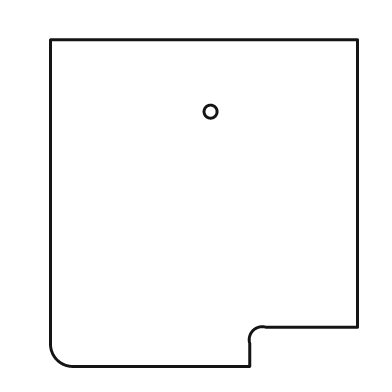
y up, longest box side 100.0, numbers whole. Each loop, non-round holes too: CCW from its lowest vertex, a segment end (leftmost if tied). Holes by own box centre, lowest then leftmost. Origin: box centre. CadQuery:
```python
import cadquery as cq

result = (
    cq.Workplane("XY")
    .moveTo(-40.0, -50.0)
    .lineTo(14.0, -50.0)
    .lineTo(14.0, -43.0)
    .threePointArc((15.0, -39.0), (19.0, -38.0))
    .lineTo(47.0, -38.0)
    .lineTo(47.0, 50.0)
    .lineTo(-47.0, 50.0)
    .lineTo(-47.0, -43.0)
    .threePointArc((-45.0, -48.0), (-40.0, -50.0))
    .close()
    .moveTo(2.0, 28.0)
    .circle(2.0)
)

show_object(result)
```